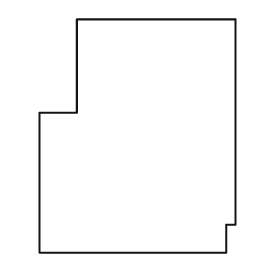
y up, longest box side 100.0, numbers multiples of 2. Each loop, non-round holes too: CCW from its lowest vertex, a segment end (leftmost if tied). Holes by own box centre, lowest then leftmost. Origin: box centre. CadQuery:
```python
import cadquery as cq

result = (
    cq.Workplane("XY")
    .moveTo(-42.0, -50.0)
    .lineTo(38.0, -50.0)
    .lineTo(38.0, -38.0)
    .lineTo(42.0, -38.0)
    .lineTo(42.0, 50.0)
    .lineTo(-26.0, 50.0)
    .lineTo(-26.0, 10.0)
    .lineTo(-42.0, 10.0)
    .close()
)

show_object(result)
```